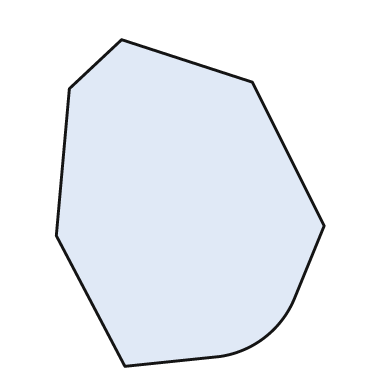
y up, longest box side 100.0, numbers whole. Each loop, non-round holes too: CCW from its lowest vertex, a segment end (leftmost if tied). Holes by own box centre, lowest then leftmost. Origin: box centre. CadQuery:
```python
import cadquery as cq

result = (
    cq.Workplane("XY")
    .moveTo(-20.0, -50.0)
    .lineTo(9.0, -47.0)
    .threePointArc((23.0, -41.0), (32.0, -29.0))
    .lineTo(41.0, -7.0)
    .lineTo(19.0, 37.0)
    .lineTo(-21.0, 50.0)
    .lineTo(-37.0, 35.0)
    .lineTo(-41.0, -10.0)
    .close()
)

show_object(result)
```